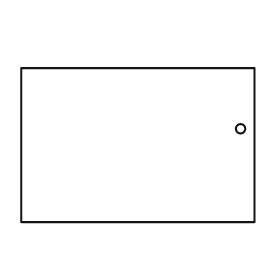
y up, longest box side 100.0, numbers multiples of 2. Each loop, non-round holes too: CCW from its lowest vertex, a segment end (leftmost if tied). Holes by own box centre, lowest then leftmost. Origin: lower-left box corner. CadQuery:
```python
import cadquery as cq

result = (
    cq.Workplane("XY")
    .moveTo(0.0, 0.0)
    .lineTo(100.0, 0.0)
    .lineTo(100.0, 66.0)
    .lineTo(0.0, 66.0)
    .close()
    .moveTo(94.0, 40.0)
    .circle(2.0)
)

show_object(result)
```